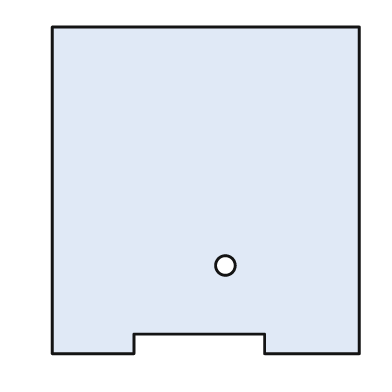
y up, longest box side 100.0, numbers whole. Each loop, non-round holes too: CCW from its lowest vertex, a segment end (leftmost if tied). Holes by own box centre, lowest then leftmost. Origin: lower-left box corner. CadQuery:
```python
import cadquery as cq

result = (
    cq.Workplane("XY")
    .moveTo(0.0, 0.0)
    .lineTo(25.0, 0.0)
    .lineTo(25.0, 6.0)
    .lineTo(65.0, 6.0)
    .lineTo(65.0, 0.0)
    .lineTo(94.0, 0.0)
    .lineTo(94.0, 100.0)
    .lineTo(0.0, 100.0)
    .close()
    .moveTo(53.0, 27.0)
    .circle(3.0)
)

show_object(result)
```